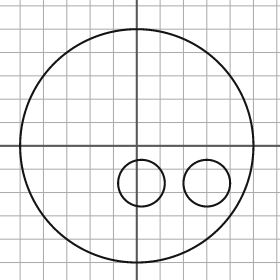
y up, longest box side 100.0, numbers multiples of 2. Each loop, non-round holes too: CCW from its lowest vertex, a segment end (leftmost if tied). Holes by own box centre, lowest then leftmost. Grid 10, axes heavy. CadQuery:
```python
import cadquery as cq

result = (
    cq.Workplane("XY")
    .moveTo(0.0, 0.0)
    .circle(50.0)
    .moveTo(2.0, -16.0)
    .circle(10.0)
    .moveTo(30.0, -16.0)
    .circle(10.0)
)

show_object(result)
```